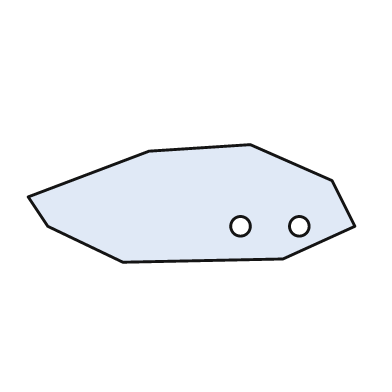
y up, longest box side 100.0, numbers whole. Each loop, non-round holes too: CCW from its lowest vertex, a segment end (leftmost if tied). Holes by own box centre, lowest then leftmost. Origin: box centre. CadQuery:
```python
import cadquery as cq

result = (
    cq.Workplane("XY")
    .moveTo(-21.0, -18.0)
    .lineTo(28.0, -17.0)
    .lineTo(50.0, -7.0)
    .lineTo(43.0, 7.0)
    .lineTo(18.0, 18.0)
    .lineTo(-13.0, 16.0)
    .lineTo(-50.0, 2.0)
    .lineTo(-44.0, -7.0)
    .close()
    .moveTo(15.0, -7.0)
    .circle(3.0)
    .moveTo(33.0, -7.0)
    .circle(3.0)
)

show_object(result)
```